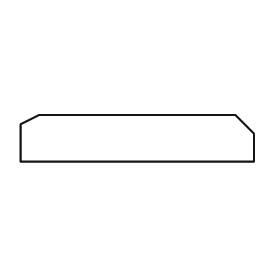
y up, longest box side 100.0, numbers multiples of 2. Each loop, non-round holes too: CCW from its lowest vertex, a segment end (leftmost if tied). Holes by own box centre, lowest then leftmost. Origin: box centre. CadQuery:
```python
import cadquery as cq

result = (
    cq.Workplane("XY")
    .moveTo(-50.0, -10.0)
    .lineTo(50.0, -10.0)
    .lineTo(50.0, 2.0)
    .lineTo(42.0, 10.0)
    .lineTo(-42.0, 10.0)
    .lineTo(-50.0, 6.0)
    .close()
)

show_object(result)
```